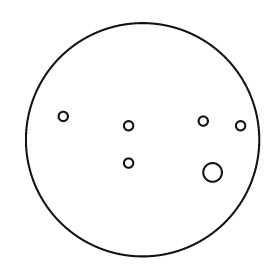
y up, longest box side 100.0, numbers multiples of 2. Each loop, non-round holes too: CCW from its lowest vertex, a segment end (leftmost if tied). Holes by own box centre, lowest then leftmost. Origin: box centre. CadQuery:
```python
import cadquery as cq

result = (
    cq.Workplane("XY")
    .moveTo(0.0, 0.0)
    .circle(50.0)
    .moveTo(30.0, -14.0)
    .circle(4.0)
    .moveTo(-6.0, -10.0)
    .circle(2.0)
    .moveTo(-6.0, 6.0)
    .circle(2.0)
    .moveTo(42.0, 6.0)
    .circle(2.0)
    .moveTo(26.0, 8.0)
    .circle(2.0)
    .moveTo(-34.0, 10.0)
    .circle(2.0)
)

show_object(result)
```